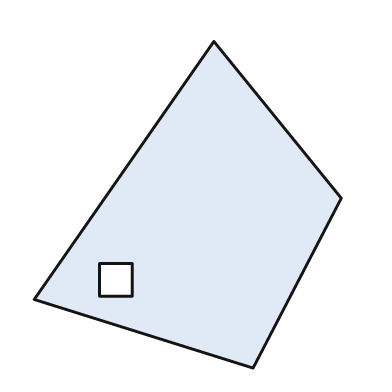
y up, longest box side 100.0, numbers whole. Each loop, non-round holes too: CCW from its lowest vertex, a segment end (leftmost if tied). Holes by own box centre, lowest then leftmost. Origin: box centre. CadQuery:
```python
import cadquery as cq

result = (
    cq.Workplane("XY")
    .moveTo(20.0, -50.0)
    .lineTo(47.0, 2.0)
    .lineTo(8.0, 50.0)
    .lineTo(-47.0, -29.0)
    .close()
    .moveTo(-27.0, -28.0)
    .lineTo(-17.0, -28.0)
    .lineTo(-17.0, -18.0)
    .lineTo(-27.0, -18.0)
    .close()
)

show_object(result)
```